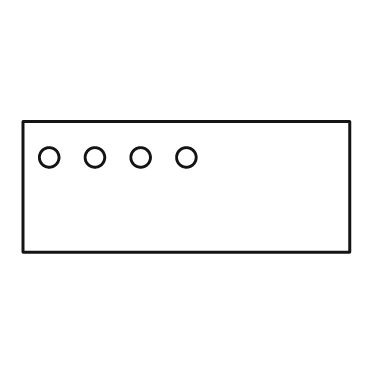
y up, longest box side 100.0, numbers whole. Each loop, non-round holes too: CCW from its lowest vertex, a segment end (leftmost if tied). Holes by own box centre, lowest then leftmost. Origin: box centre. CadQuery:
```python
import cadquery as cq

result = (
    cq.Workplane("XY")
    .moveTo(-50.0, -20.0)
    .lineTo(50.0, -20.0)
    .lineTo(50.0, 20.0)
    .lineTo(-50.0, 20.0)
    .close()
    .moveTo(-42.0, 9.0)
    .circle(3.0)
    .moveTo(-28.0, 9.0)
    .circle(3.0)
    .moveTo(-14.0, 9.0)
    .circle(3.0)
    .moveTo(0.0, 9.0)
    .circle(3.0)
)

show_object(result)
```